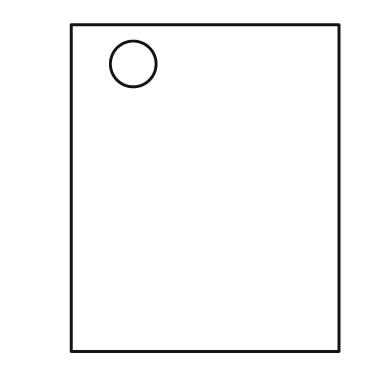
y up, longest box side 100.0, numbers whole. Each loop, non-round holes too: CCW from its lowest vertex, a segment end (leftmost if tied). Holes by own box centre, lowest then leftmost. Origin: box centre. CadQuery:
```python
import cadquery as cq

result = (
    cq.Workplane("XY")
    .moveTo(-41.0, -50.0)
    .lineTo(41.0, -50.0)
    .lineTo(41.0, 50.0)
    .lineTo(-41.0, 50.0)
    .close()
    .moveTo(-22.0, 38.0)
    .circle(7.0)
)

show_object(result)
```